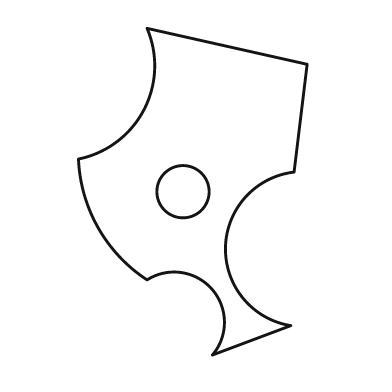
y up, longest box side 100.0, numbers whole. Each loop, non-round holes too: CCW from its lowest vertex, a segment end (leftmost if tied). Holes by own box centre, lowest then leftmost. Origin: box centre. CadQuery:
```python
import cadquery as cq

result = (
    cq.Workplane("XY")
    .moveTo(6.0, -50.0)
    .lineTo(30.0, -41.0)
    .threePointArc((10.0, -17.0), (31.0, 6.0))
    .lineTo(35.0, 39.0)
    .lineTo(-14.0, 50.0)
    .threePointArc((-15.0, 25.0), (-35.0, 10.0))
    .threePointArc((-29.0, -11.0), (-14.0, -27.0))
    .threePointArc((6.0, -30.0), (6.0, -50.0))
    .close()
    .moveTo(-3.0, 0.0)
    .circle(8.0)
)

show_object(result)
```